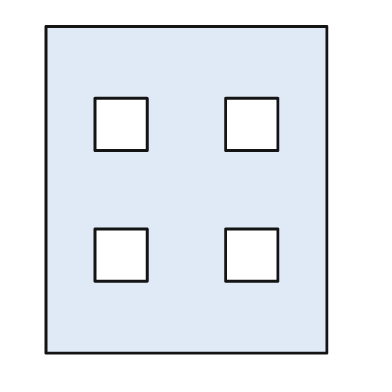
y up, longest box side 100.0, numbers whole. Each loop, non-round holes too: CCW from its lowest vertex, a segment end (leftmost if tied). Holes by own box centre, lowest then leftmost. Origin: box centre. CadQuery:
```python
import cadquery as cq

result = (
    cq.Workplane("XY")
    .moveTo(-43.0, -50.0)
    .lineTo(43.0, -50.0)
    .lineTo(43.0, 50.0)
    .lineTo(-43.0, 50.0)
    .close()
    .moveTo(-28.0, -28.0)
    .lineTo(-12.0, -28.0)
    .lineTo(-12.0, -12.0)
    .lineTo(-28.0, -12.0)
    .close()
    .moveTo(12.0, -28.0)
    .lineTo(28.0, -28.0)
    .lineTo(28.0, -12.0)
    .lineTo(12.0, -12.0)
    .close()
    .moveTo(-28.0, 12.0)
    .lineTo(-12.0, 12.0)
    .lineTo(-12.0, 28.0)
    .lineTo(-28.0, 28.0)
    .close()
    .moveTo(12.0, 12.0)
    .lineTo(28.0, 12.0)
    .lineTo(28.0, 28.0)
    .lineTo(12.0, 28.0)
    .close()
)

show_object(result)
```